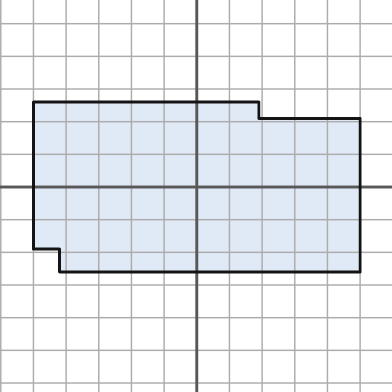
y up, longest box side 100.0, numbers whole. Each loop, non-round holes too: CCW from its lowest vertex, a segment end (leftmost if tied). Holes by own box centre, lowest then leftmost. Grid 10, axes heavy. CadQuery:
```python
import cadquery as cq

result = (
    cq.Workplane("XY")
    .moveTo(-42.0, -26.0)
    .lineTo(50.0, -26.0)
    .lineTo(50.0, 21.0)
    .lineTo(19.0, 21.0)
    .lineTo(19.0, 26.0)
    .lineTo(-50.0, 26.0)
    .lineTo(-50.0, -19.0)
    .lineTo(-42.0, -19.0)
    .close()
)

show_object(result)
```